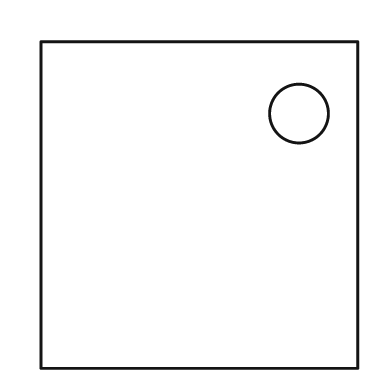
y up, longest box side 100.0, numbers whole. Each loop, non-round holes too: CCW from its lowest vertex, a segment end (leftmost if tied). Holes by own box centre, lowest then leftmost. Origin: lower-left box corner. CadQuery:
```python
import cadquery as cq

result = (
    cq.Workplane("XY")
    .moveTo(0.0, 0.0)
    .lineTo(97.0, 0.0)
    .lineTo(97.0, 100.0)
    .lineTo(0.0, 100.0)
    .close()
    .moveTo(79.0, 78.0)
    .circle(9.0)
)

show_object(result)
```